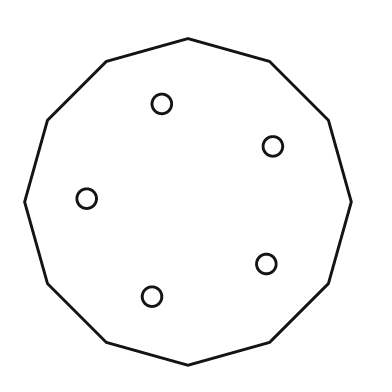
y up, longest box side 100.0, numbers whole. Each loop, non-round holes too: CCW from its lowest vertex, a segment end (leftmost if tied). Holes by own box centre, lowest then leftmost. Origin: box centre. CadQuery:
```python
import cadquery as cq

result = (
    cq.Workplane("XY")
    .moveTo(0.0, -50.0)
    .lineTo(25.0, -43.0)
    .lineTo(43.0, -25.0)
    .lineTo(50.0, 0.0)
    .lineTo(43.0, 25.0)
    .lineTo(25.0, 43.0)
    .lineTo(0.0, 50.0)
    .lineTo(-25.0, 43.0)
    .lineTo(-43.0, 25.0)
    .lineTo(-50.0, 0.0)
    .lineTo(-43.0, -25.0)
    .lineTo(-25.0, -43.0)
    .close()
    .moveTo(-11.0, -29.0)
    .circle(3.0)
    .moveTo(24.0, -19.0)
    .circle(3.0)
    .moveTo(-31.0, 1.0)
    .circle(3.0)
    .moveTo(26.0, 17.0)
    .circle(3.0)
    .moveTo(-8.0, 30.0)
    .circle(3.0)
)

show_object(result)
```